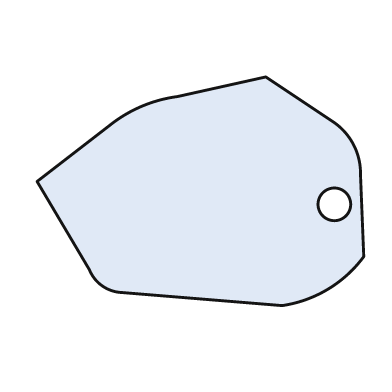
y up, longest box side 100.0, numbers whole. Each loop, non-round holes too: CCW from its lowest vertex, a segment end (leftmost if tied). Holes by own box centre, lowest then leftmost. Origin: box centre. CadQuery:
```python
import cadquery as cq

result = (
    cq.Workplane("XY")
    .moveTo(25.0, -35.0)
    .threePointArc((39.0, -30.0), (50.0, -20.0))
    .lineTo(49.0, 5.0)
    .threePointArc((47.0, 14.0), (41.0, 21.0))
    .lineTo(20.0, 35.0)
    .lineTo(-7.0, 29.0)
    .threePointArc((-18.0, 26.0), (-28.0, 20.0))
    .lineTo(-50.0, 3.0)
    .lineTo(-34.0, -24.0)
    .threePointArc((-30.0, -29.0), (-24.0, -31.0))
    .close()
    .moveTo(41.0, -4.0)
    .circle(5.0)
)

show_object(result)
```